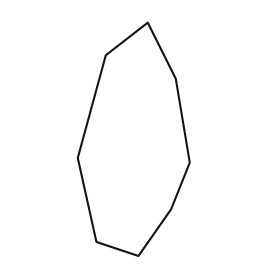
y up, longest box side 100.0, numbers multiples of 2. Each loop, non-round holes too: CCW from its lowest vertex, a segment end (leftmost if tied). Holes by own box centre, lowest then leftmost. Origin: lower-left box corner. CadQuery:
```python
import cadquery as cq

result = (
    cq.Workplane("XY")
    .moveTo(26.0, 0.0)
    .lineTo(40.0, 20.0)
    .lineTo(48.0, 40.0)
    .lineTo(42.0, 76.0)
    .lineTo(30.0, 100.0)
    .lineTo(12.0, 86.0)
    .lineTo(0.0, 42.0)
    .lineTo(8.0, 6.0)
    .close()
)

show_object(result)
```